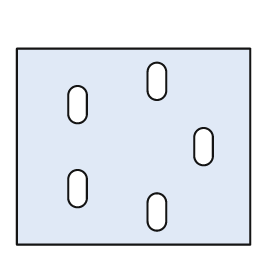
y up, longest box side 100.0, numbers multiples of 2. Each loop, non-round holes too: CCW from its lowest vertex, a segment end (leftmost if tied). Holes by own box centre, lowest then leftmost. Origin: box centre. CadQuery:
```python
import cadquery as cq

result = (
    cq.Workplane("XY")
    .moveTo(-50.0, -42.0)
    .lineTo(50.0, -42.0)
    .lineTo(50.0, 42.0)
    .lineTo(-50.0, 42.0)
    .close()
    .moveTo(6.0, -32.0)
    .threePointArc((10.0, -36.0), (14.0, -32.0))
    .lineTo(14.0, -24.0)
    .threePointArc((10.0, -20.0), (6.0, -24.0))
    .close()
    .moveTo(-28.0, -22.0)
    .threePointArc((-24.0, -26.0), (-20.0, -22.0))
    .lineTo(-20.0, -14.0)
    .threePointArc((-24.0, -10.0), (-28.0, -14.0))
    .close()
    .moveTo(26.0, -4.0)
    .threePointArc((30.0, -8.0), (34.0, -4.0))
    .lineTo(34.0, 4.0)
    .threePointArc((30.0, 8.0), (26.0, 4.0))
    .close()
    .moveTo(-28.0, 14.0)
    .threePointArc((-24.0, 10.0), (-20.0, 14.0))
    .lineTo(-20.0, 22.0)
    .threePointArc((-24.0, 26.0), (-28.0, 22.0))
    .close()
    .moveTo(6.0, 24.0)
    .threePointArc((10.0, 20.0), (14.0, 24.0))
    .lineTo(14.0, 32.0)
    .threePointArc((10.0, 36.0), (6.0, 32.0))
    .close()
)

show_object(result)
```